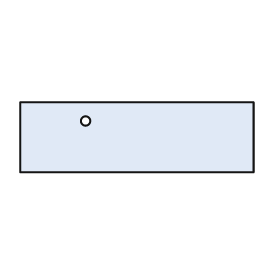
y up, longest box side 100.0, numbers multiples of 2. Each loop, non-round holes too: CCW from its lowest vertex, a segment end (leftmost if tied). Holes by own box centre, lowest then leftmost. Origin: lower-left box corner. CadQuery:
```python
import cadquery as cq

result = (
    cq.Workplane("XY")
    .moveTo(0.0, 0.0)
    .lineTo(100.0, 0.0)
    .lineTo(100.0, 30.0)
    .lineTo(0.0, 30.0)
    .close()
    .moveTo(28.0, 22.0)
    .circle(2.0)
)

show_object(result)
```